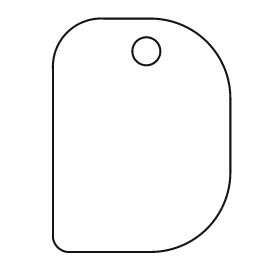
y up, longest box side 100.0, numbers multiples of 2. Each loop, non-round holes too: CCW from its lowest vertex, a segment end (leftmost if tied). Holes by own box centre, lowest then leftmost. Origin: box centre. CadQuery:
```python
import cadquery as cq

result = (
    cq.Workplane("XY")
    .moveTo(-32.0, -50.0)
    .lineTo(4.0, -50.0)
    .threePointArc((28.0, -40.0), (38.0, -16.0))
    .lineTo(38.0, 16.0)
    .threePointArc((28.0, 40.0), (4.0, 50.0))
    .lineTo(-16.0, 50.0)
    .threePointArc((-32.0, 44.0), (-38.0, 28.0))
    .lineTo(-38.0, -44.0)
    .threePointArc((-36.0, -48.0), (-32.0, -50.0))
    .close()
    .moveTo(2.0, 36.0)
    .circle(6.0)
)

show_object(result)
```